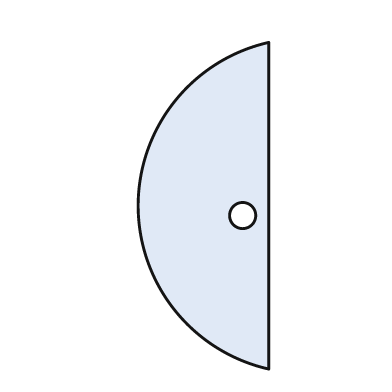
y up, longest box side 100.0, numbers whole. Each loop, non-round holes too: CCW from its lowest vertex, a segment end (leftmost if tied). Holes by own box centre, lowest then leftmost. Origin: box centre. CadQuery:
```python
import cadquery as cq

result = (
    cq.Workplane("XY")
    .moveTo(20.0, -50.0)
    .lineTo(20.0, 50.0)
    .threePointArc((-20.0, 0.0), (20.0, -50.0))
    .close()
    .moveTo(12.0, -3.0)
    .circle(4.0)
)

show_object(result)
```